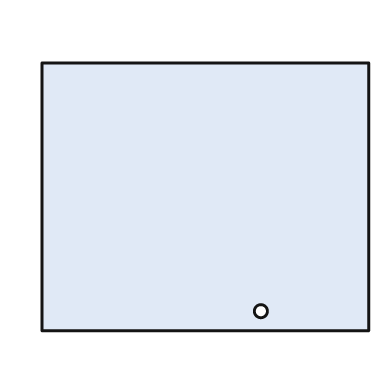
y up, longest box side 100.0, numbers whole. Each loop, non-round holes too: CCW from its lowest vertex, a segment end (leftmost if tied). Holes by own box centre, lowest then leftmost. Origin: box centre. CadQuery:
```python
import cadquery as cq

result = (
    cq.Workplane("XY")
    .moveTo(-50.0, -41.0)
    .lineTo(50.0, -41.0)
    .lineTo(50.0, 41.0)
    .lineTo(-50.0, 41.0)
    .close()
    .moveTo(17.0, -35.0)
    .circle(2.0)
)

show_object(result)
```